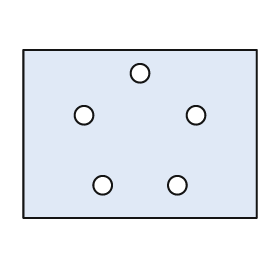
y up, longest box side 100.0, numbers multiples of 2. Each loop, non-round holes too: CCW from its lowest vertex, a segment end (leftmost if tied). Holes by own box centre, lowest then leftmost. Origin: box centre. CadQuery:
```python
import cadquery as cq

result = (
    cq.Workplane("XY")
    .moveTo(-50.0, -36.0)
    .lineTo(50.0, -36.0)
    .lineTo(50.0, 36.0)
    .lineTo(-50.0, 36.0)
    .close()
    .moveTo(-16.0, -22.0)
    .circle(4.0)
    .moveTo(16.0, -22.0)
    .circle(4.0)
    .moveTo(-24.0, 8.0)
    .circle(4.0)
    .moveTo(24.0, 8.0)
    .circle(4.0)
    .moveTo(0.0, 26.0)
    .circle(4.0)
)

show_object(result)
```